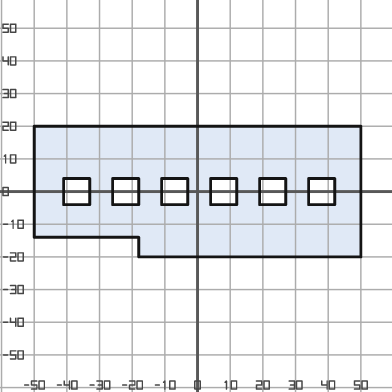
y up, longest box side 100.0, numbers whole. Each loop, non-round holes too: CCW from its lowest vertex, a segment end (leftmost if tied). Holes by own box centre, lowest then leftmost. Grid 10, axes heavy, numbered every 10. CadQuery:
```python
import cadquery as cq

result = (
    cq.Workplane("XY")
    .moveTo(-18.0, -20.0)
    .lineTo(50.0, -20.0)
    .lineTo(50.0, 20.0)
    .lineTo(-50.0, 20.0)
    .lineTo(-50.0, -14.0)
    .lineTo(-18.0, -14.0)
    .close()
    .moveTo(-41.0, -4.0)
    .lineTo(-33.0, -4.0)
    .lineTo(-33.0, 4.0)
    .lineTo(-41.0, 4.0)
    .close()
    .moveTo(-26.0, -4.0)
    .lineTo(-18.0, -4.0)
    .lineTo(-18.0, 4.0)
    .lineTo(-26.0, 4.0)
    .close()
    .moveTo(-11.0, -4.0)
    .lineTo(-3.0, -4.0)
    .lineTo(-3.0, 4.0)
    .lineTo(-11.0, 4.0)
    .close()
    .moveTo(4.0, -4.0)
    .lineTo(12.0, -4.0)
    .lineTo(12.0, 4.0)
    .lineTo(4.0, 4.0)
    .close()
    .moveTo(19.0, -4.0)
    .lineTo(27.0, -4.0)
    .lineTo(27.0, 4.0)
    .lineTo(19.0, 4.0)
    .close()
    .moveTo(34.0, -4.0)
    .lineTo(42.0, -4.0)
    .lineTo(42.0, 4.0)
    .lineTo(34.0, 4.0)
    .close()
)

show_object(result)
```